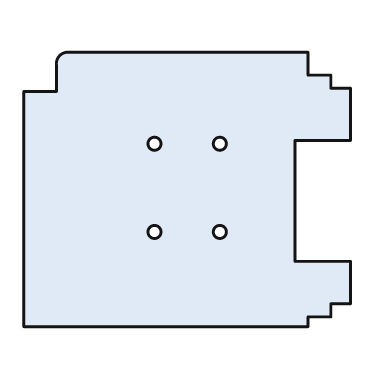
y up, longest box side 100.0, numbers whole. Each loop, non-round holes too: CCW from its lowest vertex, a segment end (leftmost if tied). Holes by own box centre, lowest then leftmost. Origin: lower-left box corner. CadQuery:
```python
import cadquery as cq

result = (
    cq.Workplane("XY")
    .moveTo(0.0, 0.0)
    .lineTo(87.0, 0.0)
    .lineTo(87.0, 3.0)
    .lineTo(94.0, 3.0)
    .lineTo(94.0, 7.0)
    .lineTo(100.0, 7.0)
    .lineTo(100.0, 20.0)
    .lineTo(83.0, 20.0)
    .lineTo(83.0, 57.0)
    .lineTo(100.0, 57.0)
    .lineTo(100.0, 73.0)
    .lineTo(94.0, 73.0)
    .lineTo(94.0, 77.0)
    .lineTo(87.0, 77.0)
    .lineTo(87.0, 84.0)
    .lineTo(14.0, 84.0)
    .threePointArc((11.0, 83.0), (10.0, 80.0))
    .lineTo(10.0, 72.0)
    .lineTo(0.0, 72.0)
    .close()
    .moveTo(40.0, 29.0)
    .circle(2.0)
    .moveTo(60.0, 29.0)
    .circle(2.0)
    .moveTo(40.0, 56.0)
    .circle(2.0)
    .moveTo(60.0, 56.0)
    .circle(2.0)
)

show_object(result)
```